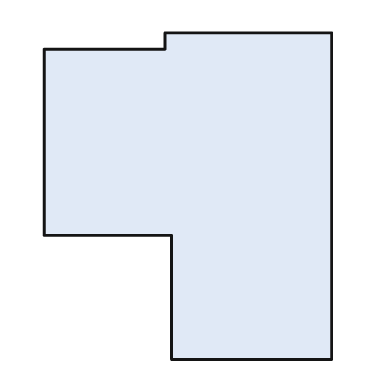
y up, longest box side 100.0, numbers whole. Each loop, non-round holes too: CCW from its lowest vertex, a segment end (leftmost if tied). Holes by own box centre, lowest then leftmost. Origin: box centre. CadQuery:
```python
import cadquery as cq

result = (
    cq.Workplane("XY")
    .moveTo(-5.0, -50.0)
    .lineTo(44.0, -50.0)
    .lineTo(44.0, 50.0)
    .lineTo(-7.0, 50.0)
    .lineTo(-7.0, 45.0)
    .lineTo(-44.0, 45.0)
    .lineTo(-44.0, -12.0)
    .lineTo(-5.0, -12.0)
    .close()
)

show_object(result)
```